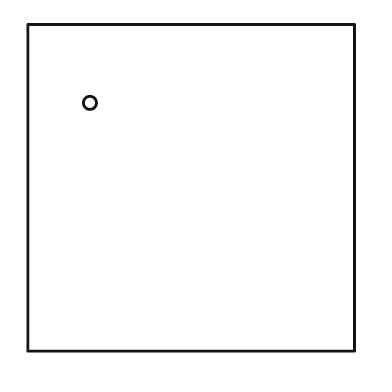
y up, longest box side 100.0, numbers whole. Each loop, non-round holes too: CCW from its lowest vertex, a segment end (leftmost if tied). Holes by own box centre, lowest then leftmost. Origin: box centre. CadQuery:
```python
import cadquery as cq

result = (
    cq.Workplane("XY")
    .moveTo(-50.0, -50.0)
    .lineTo(50.0, -50.0)
    .lineTo(50.0, 50.0)
    .lineTo(-50.0, 50.0)
    .close()
    .moveTo(-31.0, 26.0)
    .circle(2.0)
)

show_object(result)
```